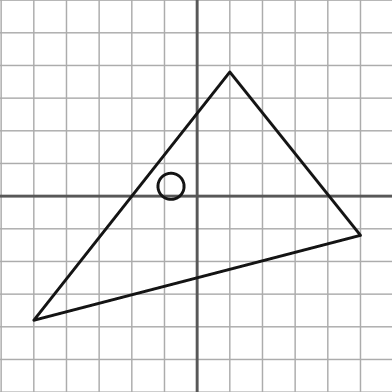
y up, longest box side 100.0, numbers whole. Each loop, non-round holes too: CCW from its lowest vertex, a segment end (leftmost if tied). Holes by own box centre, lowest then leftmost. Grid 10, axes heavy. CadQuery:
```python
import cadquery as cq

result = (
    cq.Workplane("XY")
    .moveTo(-50.0, -38.0)
    .lineTo(50.0, -12.0)
    .lineTo(10.0, 38.0)
    .close()
    .moveTo(-8.0, 3.0)
    .circle(4.0)
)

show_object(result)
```